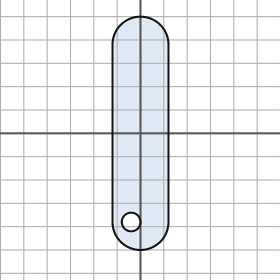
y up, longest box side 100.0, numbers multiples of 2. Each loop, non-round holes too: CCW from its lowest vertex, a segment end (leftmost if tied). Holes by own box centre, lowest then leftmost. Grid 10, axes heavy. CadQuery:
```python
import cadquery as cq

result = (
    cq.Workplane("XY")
    .moveTo(-12.0, -38.0)
    .threePointArc((0.0, -50.0), (12.0, -38.0))
    .lineTo(12.0, 38.0)
    .threePointArc((0.0, 50.0), (-12.0, 38.0))
    .close()
    .moveTo(-4.0, -38.0)
    .circle(4.0)
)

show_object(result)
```